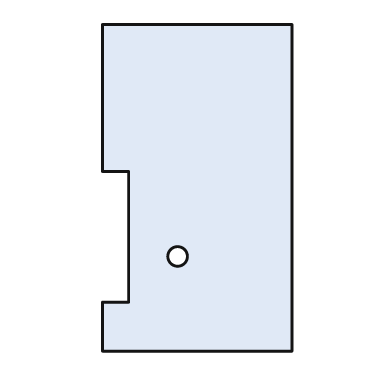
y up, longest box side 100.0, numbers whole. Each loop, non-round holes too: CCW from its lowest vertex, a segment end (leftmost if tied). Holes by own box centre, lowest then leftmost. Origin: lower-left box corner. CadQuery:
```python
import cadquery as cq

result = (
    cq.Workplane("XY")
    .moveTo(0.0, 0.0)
    .lineTo(58.0, 0.0)
    .lineTo(58.0, 100.0)
    .lineTo(0.0, 100.0)
    .lineTo(0.0, 55.0)
    .lineTo(8.0, 55.0)
    .lineTo(8.0, 15.0)
    .lineTo(0.0, 15.0)
    .close()
    .moveTo(23.0, 29.0)
    .circle(3.0)
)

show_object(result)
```